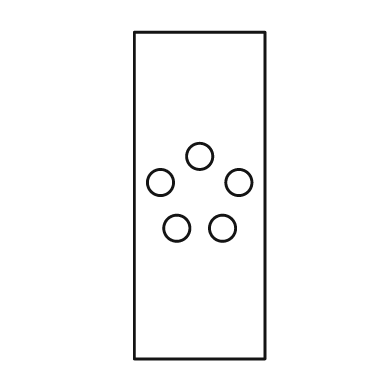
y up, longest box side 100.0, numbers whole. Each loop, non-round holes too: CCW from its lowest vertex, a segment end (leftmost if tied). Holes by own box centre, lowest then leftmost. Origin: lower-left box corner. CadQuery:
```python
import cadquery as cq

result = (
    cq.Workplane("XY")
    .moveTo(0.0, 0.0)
    .lineTo(40.0, 0.0)
    .lineTo(40.0, 100.0)
    .lineTo(0.0, 100.0)
    .close()
    .moveTo(13.0, 40.0)
    .circle(4.0)
    .moveTo(27.0, 40.0)
    .circle(4.0)
    .moveTo(8.0, 54.0)
    .circle(4.0)
    .moveTo(32.0, 54.0)
    .circle(4.0)
    .moveTo(20.0, 62.0)
    .circle(4.0)
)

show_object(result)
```